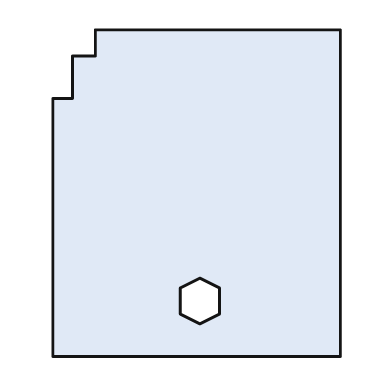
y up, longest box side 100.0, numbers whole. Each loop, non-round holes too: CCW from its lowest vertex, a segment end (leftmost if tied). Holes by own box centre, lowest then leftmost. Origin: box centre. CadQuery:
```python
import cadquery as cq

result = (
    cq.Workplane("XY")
    .moveTo(-44.0, -50.0)
    .lineTo(44.0, -50.0)
    .lineTo(44.0, 50.0)
    .lineTo(-31.0, 50.0)
    .lineTo(-31.0, 42.0)
    .lineTo(-38.0, 42.0)
    .lineTo(-38.0, 29.0)
    .lineTo(-44.0, 29.0)
    .close()
    .moveTo(1.0, -40.0)
    .lineTo(7.0, -37.0)
    .lineTo(7.0, -29.0)
    .lineTo(1.0, -26.0)
    .lineTo(-5.0, -29.0)
    .lineTo(-5.0, -37.0)
    .close()
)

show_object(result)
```